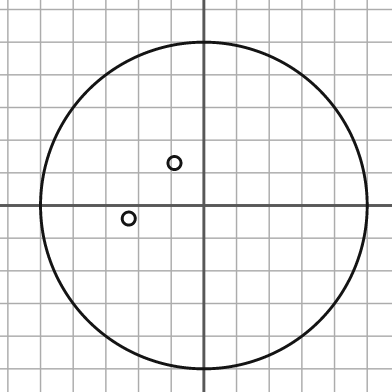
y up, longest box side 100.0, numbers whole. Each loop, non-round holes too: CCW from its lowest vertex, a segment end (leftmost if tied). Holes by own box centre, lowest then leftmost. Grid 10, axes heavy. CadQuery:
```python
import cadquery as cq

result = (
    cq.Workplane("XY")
    .moveTo(0.0, 0.0)
    .circle(50.0)
    .moveTo(-23.0, -4.0)
    .circle(2.0)
    .moveTo(-9.0, 13.0)
    .circle(2.0)
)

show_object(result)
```